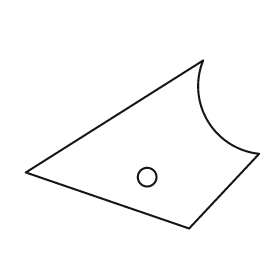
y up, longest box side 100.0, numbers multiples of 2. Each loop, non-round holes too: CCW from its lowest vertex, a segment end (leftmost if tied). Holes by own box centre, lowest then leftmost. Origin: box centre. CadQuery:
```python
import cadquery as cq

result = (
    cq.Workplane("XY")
    .moveTo(20.0, -36.0)
    .lineTo(50.0, -4.0)
    .threePointArc((28.0, 10.0), (26.0, 36.0))
    .lineTo(-50.0, -12.0)
    .close()
    .moveTo(2.0, -14.0)
    .circle(4.0)
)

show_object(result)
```